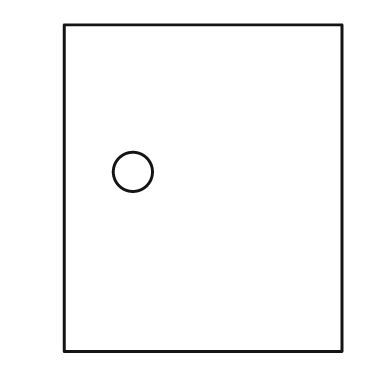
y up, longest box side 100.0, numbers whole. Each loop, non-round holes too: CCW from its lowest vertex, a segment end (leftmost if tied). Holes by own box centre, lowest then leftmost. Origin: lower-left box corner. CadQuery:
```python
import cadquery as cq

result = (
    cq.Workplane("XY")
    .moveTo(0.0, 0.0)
    .lineTo(85.0, 0.0)
    .lineTo(85.0, 100.0)
    .lineTo(0.0, 100.0)
    .close()
    .moveTo(21.0, 55.0)
    .circle(6.0)
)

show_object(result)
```